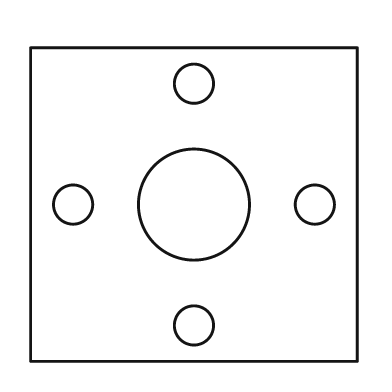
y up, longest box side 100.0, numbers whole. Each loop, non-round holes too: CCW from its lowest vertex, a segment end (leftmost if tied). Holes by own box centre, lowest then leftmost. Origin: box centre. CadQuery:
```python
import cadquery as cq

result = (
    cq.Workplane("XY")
    .moveTo(-50.0, -48.0)
    .lineTo(50.0, -48.0)
    .lineTo(50.0, 48.0)
    .lineTo(-50.0, 48.0)
    .close()
    .moveTo(0.0, -37.0)
    .circle(6.0)
    .moveTo(-37.0, 0.0)
    .circle(6.0)
    .moveTo(0.0, 0.0)
    .circle(17.0)
    .moveTo(37.0, 0.0)
    .circle(6.0)
    .moveTo(0.0, 37.0)
    .circle(6.0)
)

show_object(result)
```